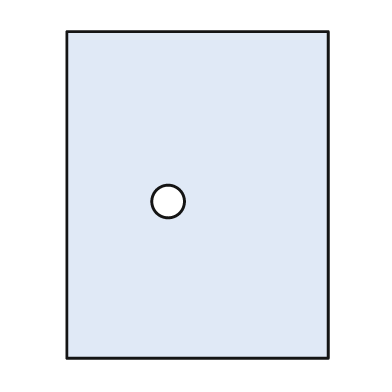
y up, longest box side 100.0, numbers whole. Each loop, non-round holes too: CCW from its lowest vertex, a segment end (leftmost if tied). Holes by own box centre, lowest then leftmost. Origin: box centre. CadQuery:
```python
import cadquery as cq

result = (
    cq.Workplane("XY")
    .moveTo(-40.0, -50.0)
    .lineTo(40.0, -50.0)
    .lineTo(40.0, 50.0)
    .lineTo(-40.0, 50.0)
    .close()
    .moveTo(-9.0, -2.0)
    .circle(5.0)
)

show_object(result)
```